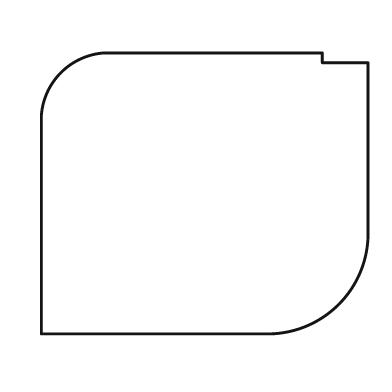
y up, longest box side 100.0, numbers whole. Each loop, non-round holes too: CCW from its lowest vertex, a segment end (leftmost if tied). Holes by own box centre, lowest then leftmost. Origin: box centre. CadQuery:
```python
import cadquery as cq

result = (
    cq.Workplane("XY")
    .moveTo(-50.0, -43.0)
    .lineTo(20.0, -43.0)
    .threePointArc((41.0, -34.0), (50.0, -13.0))
    .lineTo(50.0, 40.0)
    .lineTo(36.0, 40.0)
    .lineTo(36.0, 43.0)
    .lineTo(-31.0, 43.0)
    .threePointArc((-44.0, 37.0), (-50.0, 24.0))
    .close()
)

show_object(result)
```